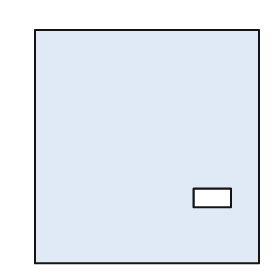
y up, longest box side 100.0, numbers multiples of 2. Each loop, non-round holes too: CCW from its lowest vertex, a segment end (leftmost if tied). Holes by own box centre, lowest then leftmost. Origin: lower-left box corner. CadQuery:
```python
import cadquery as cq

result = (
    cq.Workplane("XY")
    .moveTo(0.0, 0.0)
    .lineTo(96.0, 0.0)
    .lineTo(96.0, 100.0)
    .lineTo(0.0, 100.0)
    .close()
    .moveTo(68.0, 24.0)
    .lineTo(84.0, 24.0)
    .lineTo(84.0, 32.0)
    .lineTo(68.0, 32.0)
    .close()
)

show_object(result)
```